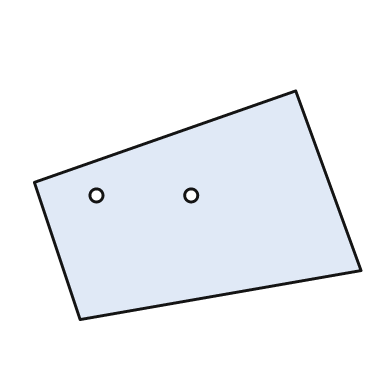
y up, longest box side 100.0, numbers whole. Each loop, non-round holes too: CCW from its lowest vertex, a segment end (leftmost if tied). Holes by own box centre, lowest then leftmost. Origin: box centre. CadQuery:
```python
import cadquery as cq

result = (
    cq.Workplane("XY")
    .moveTo(-36.0, -35.0)
    .lineTo(50.0, -20.0)
    .lineTo(30.0, 35.0)
    .lineTo(-50.0, 7.0)
    .close()
    .moveTo(-31.0, 3.0)
    .circle(2.0)
    .moveTo(-2.0, 3.0)
    .circle(2.0)
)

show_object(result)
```